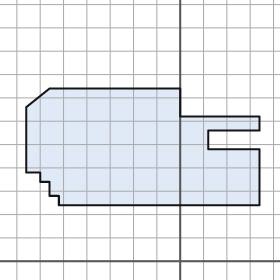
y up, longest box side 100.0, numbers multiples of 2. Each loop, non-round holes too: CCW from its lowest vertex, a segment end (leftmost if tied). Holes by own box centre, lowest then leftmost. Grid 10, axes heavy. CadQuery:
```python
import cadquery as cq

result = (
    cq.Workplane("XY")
    .moveTo(-52.0, 24.0)
    .lineTo(34.0, 24.0)
    .lineTo(34.0, 48.0)
    .lineTo(12.0, 48.0)
    .lineTo(12.0, 56.0)
    .lineTo(34.0, 56.0)
    .lineTo(34.0, 62.0)
    .lineTo(0.0, 62.0)
    .lineTo(0.0, 74.0)
    .lineTo(-56.0, 74.0)
    .lineTo(-66.0, 66.0)
    .lineTo(-66.0, 38.0)
    .lineTo(-60.0, 38.0)
    .lineTo(-60.0, 34.0)
    .lineTo(-56.0, 34.0)
    .lineTo(-56.0, 28.0)
    .lineTo(-52.0, 28.0)
    .close()
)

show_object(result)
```